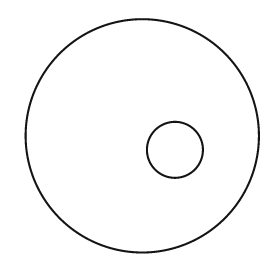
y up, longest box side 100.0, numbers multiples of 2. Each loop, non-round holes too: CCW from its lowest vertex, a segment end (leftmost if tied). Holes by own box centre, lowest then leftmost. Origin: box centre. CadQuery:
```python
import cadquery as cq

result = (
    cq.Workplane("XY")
    .moveTo(0.0, 0.0)
    .circle(50.0)
    .moveTo(14.0, -6.0)
    .circle(12.0)
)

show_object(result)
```